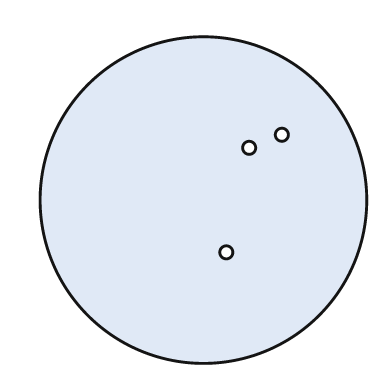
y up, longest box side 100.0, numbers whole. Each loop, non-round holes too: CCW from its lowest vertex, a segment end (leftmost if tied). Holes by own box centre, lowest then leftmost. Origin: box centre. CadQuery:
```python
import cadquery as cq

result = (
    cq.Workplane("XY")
    .moveTo(0.0, 0.0)
    .circle(50.0)
    .moveTo(7.0, -16.0)
    .circle(2.0)
    .moveTo(14.0, 16.0)
    .circle(2.0)
    .moveTo(24.0, 20.0)
    .circle(2.0)
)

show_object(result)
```